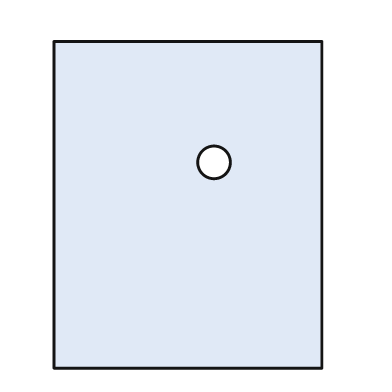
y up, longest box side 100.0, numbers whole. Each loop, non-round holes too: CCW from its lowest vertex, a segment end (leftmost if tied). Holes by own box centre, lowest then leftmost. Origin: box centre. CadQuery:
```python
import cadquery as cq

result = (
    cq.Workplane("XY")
    .moveTo(-41.0, -50.0)
    .lineTo(41.0, -50.0)
    .lineTo(41.0, 50.0)
    .lineTo(-41.0, 50.0)
    .close()
    .moveTo(8.0, 13.0)
    .circle(5.0)
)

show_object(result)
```